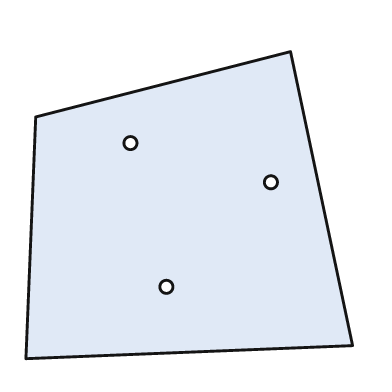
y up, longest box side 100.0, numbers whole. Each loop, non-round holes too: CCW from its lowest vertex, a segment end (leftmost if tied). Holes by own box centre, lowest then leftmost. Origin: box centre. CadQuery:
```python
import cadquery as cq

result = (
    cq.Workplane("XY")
    .moveTo(-50.0, -47.0)
    .lineTo(50.0, -43.0)
    .lineTo(31.0, 47.0)
    .lineTo(-47.0, 27.0)
    .close()
    .moveTo(-7.0, -25.0)
    .circle(2.0)
    .moveTo(25.0, 7.0)
    .circle(2.0)
    .moveTo(-18.0, 19.0)
    .circle(2.0)
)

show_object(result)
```